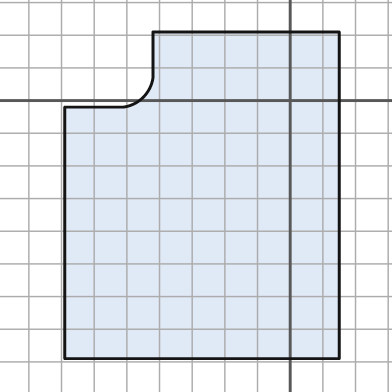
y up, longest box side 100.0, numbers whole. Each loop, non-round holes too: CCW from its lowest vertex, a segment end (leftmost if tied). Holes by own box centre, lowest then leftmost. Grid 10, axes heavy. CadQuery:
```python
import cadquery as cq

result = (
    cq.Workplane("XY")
    .moveTo(-69.0, -79.0)
    .lineTo(15.0, -79.0)
    .lineTo(15.0, 21.0)
    .lineTo(-42.0, 21.0)
    .lineTo(-42.0, 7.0)
    .threePointArc((-45.0, 1.0), (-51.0, -2.0))
    .lineTo(-69.0, -2.0)
    .close()
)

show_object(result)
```